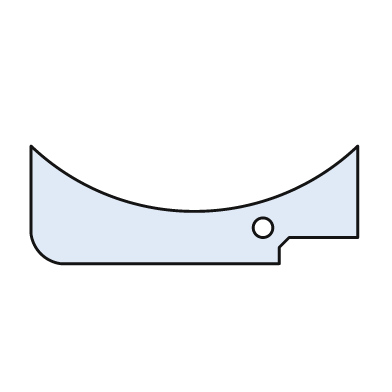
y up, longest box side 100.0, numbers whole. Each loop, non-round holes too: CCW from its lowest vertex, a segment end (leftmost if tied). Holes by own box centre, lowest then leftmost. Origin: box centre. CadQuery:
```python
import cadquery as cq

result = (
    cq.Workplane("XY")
    .moveTo(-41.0, -18.0)
    .lineTo(26.0, -18.0)
    .lineTo(26.0, -13.0)
    .lineTo(29.0, -10.0)
    .lineTo(50.0, -10.0)
    .lineTo(50.0, 18.0)
    .threePointArc((0.0, -2.0), (-50.0, 18.0))
    .lineTo(-50.0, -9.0)
    .threePointArc((-47.0, -15.0), (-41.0, -18.0))
    .close()
    .moveTo(21.0, -7.0)
    .circle(3.0)
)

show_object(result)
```